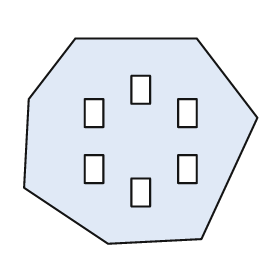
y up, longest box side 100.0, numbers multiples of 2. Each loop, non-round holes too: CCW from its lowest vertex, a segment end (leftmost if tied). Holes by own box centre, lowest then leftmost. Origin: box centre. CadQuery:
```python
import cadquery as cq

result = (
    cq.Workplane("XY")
    .moveTo(-14.0, -44.0)
    .lineTo(26.0, -42.0)
    .lineTo(50.0, 10.0)
    .lineTo(24.0, 44.0)
    .lineTo(-28.0, 44.0)
    .lineTo(-48.0, 18.0)
    .lineTo(-50.0, -20.0)
    .close()
    .moveTo(-4.0, -28.0)
    .lineTo(4.0, -28.0)
    .lineTo(4.0, -16.0)
    .lineTo(-4.0, -16.0)
    .close()
    .moveTo(-24.0, -18.0)
    .lineTo(-16.0, -18.0)
    .lineTo(-16.0, -6.0)
    .lineTo(-24.0, -6.0)
    .close()
    .moveTo(16.0, -18.0)
    .lineTo(24.0, -18.0)
    .lineTo(24.0, -6.0)
    .lineTo(16.0, -6.0)
    .close()
    .moveTo(-24.0, 6.0)
    .lineTo(-16.0, 6.0)
    .lineTo(-16.0, 18.0)
    .lineTo(-24.0, 18.0)
    .close()
    .moveTo(16.0, 6.0)
    .lineTo(24.0, 6.0)
    .lineTo(24.0, 18.0)
    .lineTo(16.0, 18.0)
    .close()
    .moveTo(-4.0, 16.0)
    .lineTo(4.0, 16.0)
    .lineTo(4.0, 28.0)
    .lineTo(-4.0, 28.0)
    .close()
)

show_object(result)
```